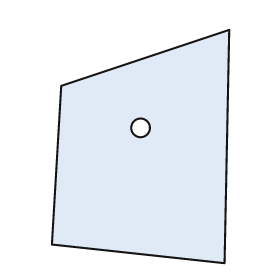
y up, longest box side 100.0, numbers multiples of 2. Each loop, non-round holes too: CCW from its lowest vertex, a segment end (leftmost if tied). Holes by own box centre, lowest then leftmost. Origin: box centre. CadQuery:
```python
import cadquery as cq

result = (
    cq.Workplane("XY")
    .moveTo(36.0, -50.0)
    .lineTo(38.0, 50.0)
    .lineTo(-34.0, 26.0)
    .lineTo(-38.0, -42.0)
    .close()
    .moveTo(0.0, 8.0)
    .circle(4.0)
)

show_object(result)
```